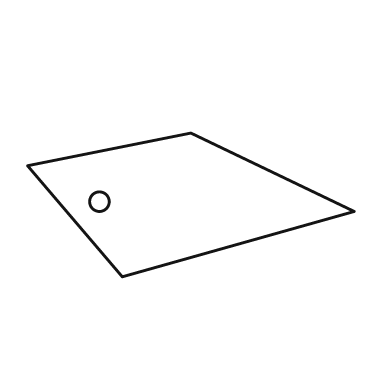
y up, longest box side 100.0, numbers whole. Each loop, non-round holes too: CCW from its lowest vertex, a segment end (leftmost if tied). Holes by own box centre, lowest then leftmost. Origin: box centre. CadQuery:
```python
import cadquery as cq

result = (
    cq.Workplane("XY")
    .moveTo(-21.0, -22.0)
    .lineTo(50.0, -2.0)
    .lineTo(0.0, 22.0)
    .lineTo(-50.0, 12.0)
    .close()
    .moveTo(-28.0, 1.0)
    .circle(3.0)
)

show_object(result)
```